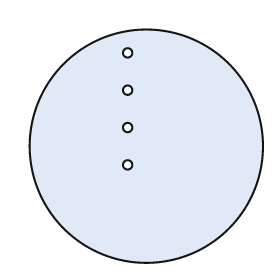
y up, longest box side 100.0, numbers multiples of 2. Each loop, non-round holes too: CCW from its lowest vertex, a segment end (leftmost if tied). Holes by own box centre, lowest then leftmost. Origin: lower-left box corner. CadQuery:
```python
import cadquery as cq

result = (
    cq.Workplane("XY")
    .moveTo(50.0, 50.0)
    .circle(50.0)
    .moveTo(42.0, 42.0)
    .circle(2.0)
    .moveTo(42.0, 58.0)
    .circle(2.0)
    .moveTo(42.0, 74.0)
    .circle(2.0)
    .moveTo(42.0, 90.0)
    .circle(2.0)
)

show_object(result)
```